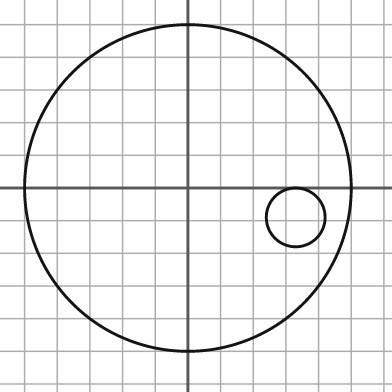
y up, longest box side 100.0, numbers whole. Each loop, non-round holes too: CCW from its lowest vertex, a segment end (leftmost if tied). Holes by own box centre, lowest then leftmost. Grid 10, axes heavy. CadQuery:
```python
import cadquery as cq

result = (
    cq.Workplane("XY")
    .moveTo(0.0, 0.0)
    .circle(50.0)
    .moveTo(33.0, -9.0)
    .circle(9.0)
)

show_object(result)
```